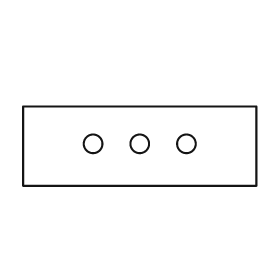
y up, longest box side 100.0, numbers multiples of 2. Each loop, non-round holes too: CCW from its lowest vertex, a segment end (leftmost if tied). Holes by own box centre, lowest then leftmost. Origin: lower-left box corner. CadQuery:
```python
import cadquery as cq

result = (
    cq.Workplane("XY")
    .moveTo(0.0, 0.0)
    .lineTo(100.0, 0.0)
    .lineTo(100.0, 34.0)
    .lineTo(0.0, 34.0)
    .close()
    .moveTo(30.0, 18.0)
    .circle(4.0)
    .moveTo(50.0, 18.0)
    .circle(4.0)
    .moveTo(70.0, 18.0)
    .circle(4.0)
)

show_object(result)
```